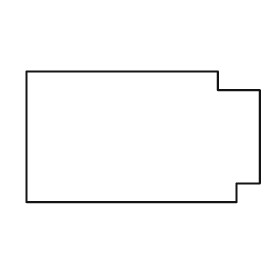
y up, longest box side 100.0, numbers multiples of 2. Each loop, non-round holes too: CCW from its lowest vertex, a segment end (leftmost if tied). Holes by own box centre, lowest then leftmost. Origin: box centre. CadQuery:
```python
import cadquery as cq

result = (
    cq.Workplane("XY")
    .moveTo(-50.0, -28.0)
    .lineTo(40.0, -28.0)
    .lineTo(40.0, -20.0)
    .lineTo(50.0, -20.0)
    .lineTo(50.0, 20.0)
    .lineTo(32.0, 20.0)
    .lineTo(32.0, 28.0)
    .lineTo(-50.0, 28.0)
    .close()
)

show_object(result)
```